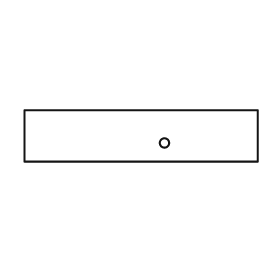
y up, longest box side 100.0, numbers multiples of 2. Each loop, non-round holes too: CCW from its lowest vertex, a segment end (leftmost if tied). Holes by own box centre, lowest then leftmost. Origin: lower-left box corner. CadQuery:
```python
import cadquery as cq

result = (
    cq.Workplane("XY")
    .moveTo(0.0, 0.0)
    .lineTo(100.0, 0.0)
    .lineTo(100.0, 22.0)
    .lineTo(0.0, 22.0)
    .close()
    .moveTo(60.0, 8.0)
    .circle(2.0)
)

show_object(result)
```